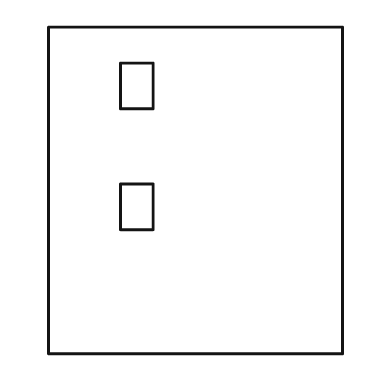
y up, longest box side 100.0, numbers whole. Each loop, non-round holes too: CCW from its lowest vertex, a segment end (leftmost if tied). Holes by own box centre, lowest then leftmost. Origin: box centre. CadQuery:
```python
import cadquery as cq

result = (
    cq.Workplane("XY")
    .moveTo(-45.0, -50.0)
    .lineTo(45.0, -50.0)
    .lineTo(45.0, 50.0)
    .lineTo(-45.0, 50.0)
    .close()
    .moveTo(-23.0, -12.0)
    .lineTo(-13.0, -12.0)
    .lineTo(-13.0, 2.0)
    .lineTo(-23.0, 2.0)
    .close()
    .moveTo(-23.0, 25.0)
    .lineTo(-13.0, 25.0)
    .lineTo(-13.0, 39.0)
    .lineTo(-23.0, 39.0)
    .close()
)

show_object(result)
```